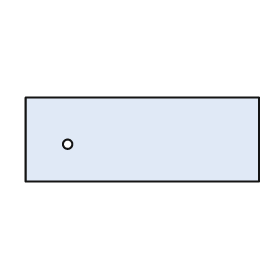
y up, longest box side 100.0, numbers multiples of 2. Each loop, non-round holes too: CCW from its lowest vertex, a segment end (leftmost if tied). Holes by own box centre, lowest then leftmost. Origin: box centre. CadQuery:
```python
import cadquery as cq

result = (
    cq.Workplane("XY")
    .moveTo(-50.0, -18.0)
    .lineTo(50.0, -18.0)
    .lineTo(50.0, 18.0)
    .lineTo(-50.0, 18.0)
    .close()
    .moveTo(-32.0, -2.0)
    .circle(2.0)
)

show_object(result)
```